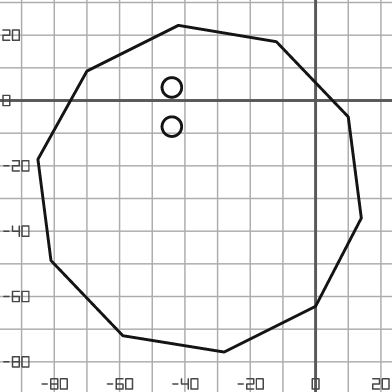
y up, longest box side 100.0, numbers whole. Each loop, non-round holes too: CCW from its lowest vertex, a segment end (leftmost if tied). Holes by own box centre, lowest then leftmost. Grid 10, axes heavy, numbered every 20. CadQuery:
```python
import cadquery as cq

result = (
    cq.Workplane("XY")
    .moveTo(-28.0, -77.0)
    .lineTo(0.0, -63.0)
    .lineTo(14.0, -36.0)
    .lineTo(10.0, -5.0)
    .lineTo(-12.0, 18.0)
    .lineTo(-42.0, 23.0)
    .lineTo(-70.0, 9.0)
    .lineTo(-85.0, -18.0)
    .lineTo(-81.0, -49.0)
    .lineTo(-59.0, -72.0)
    .close()
    .moveTo(-44.0, -8.0)
    .circle(3.0)
    .moveTo(-44.0, 4.0)
    .circle(3.0)
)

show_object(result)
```